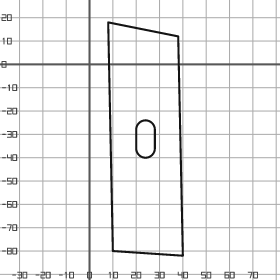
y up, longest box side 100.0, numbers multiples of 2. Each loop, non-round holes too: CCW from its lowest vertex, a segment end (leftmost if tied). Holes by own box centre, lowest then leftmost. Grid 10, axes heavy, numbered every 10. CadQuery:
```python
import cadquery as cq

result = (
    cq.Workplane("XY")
    .moveTo(40.0, -82.0)
    .lineTo(38.0, 12.0)
    .lineTo(8.0, 18.0)
    .lineTo(10.0, -80.0)
    .close()
    .moveTo(20.0, -36.0)
    .threePointArc((24.0, -40.0), (28.0, -36.0))
    .lineTo(28.0, -28.0)
    .threePointArc((24.0, -24.0), (20.0, -28.0))
    .close()
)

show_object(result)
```